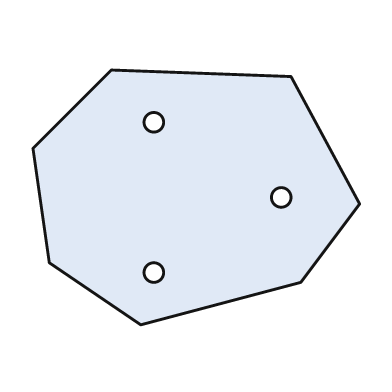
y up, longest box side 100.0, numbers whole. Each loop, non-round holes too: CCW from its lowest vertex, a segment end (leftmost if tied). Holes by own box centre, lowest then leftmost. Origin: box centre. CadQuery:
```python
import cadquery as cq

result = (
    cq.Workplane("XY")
    .moveTo(-17.0, -39.0)
    .lineTo(32.0, -26.0)
    .lineTo(50.0, -2.0)
    .lineTo(29.0, 37.0)
    .lineTo(-26.0, 39.0)
    .lineTo(-50.0, 15.0)
    .lineTo(-45.0, -20.0)
    .close()
    .moveTo(-13.0, -23.0)
    .circle(3.0)
    .moveTo(26.0, 0.0)
    .circle(3.0)
    .moveTo(-13.0, 23.0)
    .circle(3.0)
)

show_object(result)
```